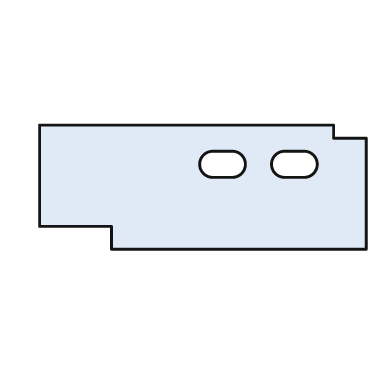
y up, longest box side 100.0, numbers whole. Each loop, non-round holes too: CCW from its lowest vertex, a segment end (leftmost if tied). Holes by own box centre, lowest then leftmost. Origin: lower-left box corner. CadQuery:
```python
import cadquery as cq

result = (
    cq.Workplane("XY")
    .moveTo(22.0, 0.0)
    .lineTo(100.0, 0.0)
    .lineTo(100.0, 34.0)
    .lineTo(90.0, 34.0)
    .lineTo(90.0, 38.0)
    .lineTo(0.0, 38.0)
    .lineTo(0.0, 7.0)
    .lineTo(22.0, 7.0)
    .close()
    .moveTo(53.0, 22.0)
    .lineTo(59.0, 22.0)
    .threePointArc((63.0, 26.0), (59.0, 30.0))
    .lineTo(53.0, 30.0)
    .threePointArc((49.0, 26.0), (53.0, 22.0))
    .close()
    .moveTo(75.0, 22.0)
    .lineTo(81.0, 22.0)
    .threePointArc((85.0, 26.0), (81.0, 30.0))
    .lineTo(75.0, 30.0)
    .threePointArc((71.0, 26.0), (75.0, 22.0))
    .close()
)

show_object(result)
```